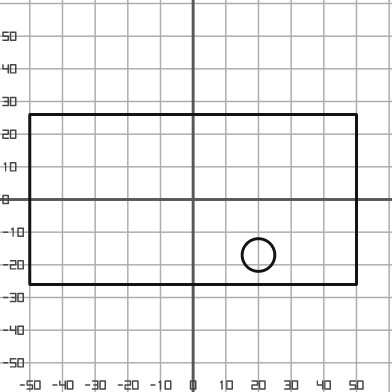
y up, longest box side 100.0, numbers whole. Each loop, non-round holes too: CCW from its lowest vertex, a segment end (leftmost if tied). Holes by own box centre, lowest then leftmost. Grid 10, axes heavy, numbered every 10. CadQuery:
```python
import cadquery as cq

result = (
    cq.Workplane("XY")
    .moveTo(-50.0, -26.0)
    .lineTo(50.0, -26.0)
    .lineTo(50.0, 26.0)
    .lineTo(-50.0, 26.0)
    .close()
    .moveTo(20.0, -17.0)
    .circle(5.0)
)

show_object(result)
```